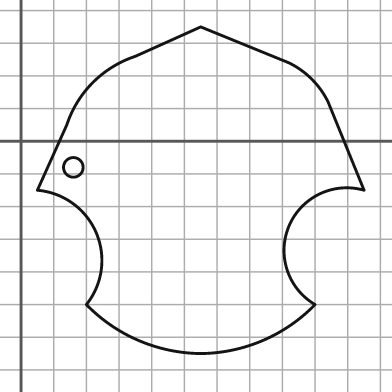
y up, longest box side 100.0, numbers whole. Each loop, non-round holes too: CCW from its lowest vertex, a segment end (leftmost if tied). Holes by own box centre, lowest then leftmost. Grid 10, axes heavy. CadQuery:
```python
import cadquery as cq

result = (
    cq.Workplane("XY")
    .moveTo(55.0, -65.0)
    .threePointArc((74.0, -61.0), (90.0, -50.0))
    .threePointArc((82.0, -26.0), (105.0, -15.0))
    .lineTo(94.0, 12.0)
    .threePointArc((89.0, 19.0), (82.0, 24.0))
    .lineTo(55.0, 35.0)
    .lineTo(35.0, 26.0)
    .threePointArc((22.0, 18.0), (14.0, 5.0))
    .lineTo(5.0, -15.0)
    .threePointArc((23.0, -28.0), (20.0, -50.0))
    .threePointArc((36.0, -61.0), (55.0, -65.0))
    .close()
    .moveTo(16.0, -8.0)
    .circle(3.0)
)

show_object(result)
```